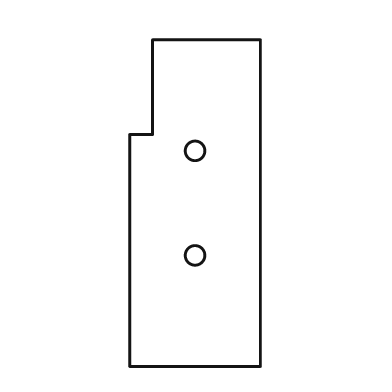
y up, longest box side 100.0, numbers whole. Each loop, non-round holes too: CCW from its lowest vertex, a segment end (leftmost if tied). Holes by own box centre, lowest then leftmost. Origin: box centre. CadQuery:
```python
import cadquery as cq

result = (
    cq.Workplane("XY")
    .moveTo(-20.0, -50.0)
    .lineTo(20.0, -50.0)
    .lineTo(20.0, 50.0)
    .lineTo(-13.0, 50.0)
    .lineTo(-13.0, 21.0)
    .lineTo(-20.0, 21.0)
    .close()
    .moveTo(0.0, -16.0)
    .circle(3.0)
    .moveTo(0.0, 16.0)
    .circle(3.0)
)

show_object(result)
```